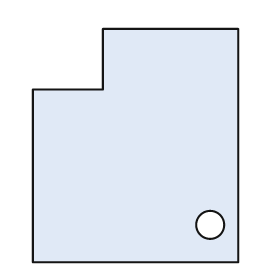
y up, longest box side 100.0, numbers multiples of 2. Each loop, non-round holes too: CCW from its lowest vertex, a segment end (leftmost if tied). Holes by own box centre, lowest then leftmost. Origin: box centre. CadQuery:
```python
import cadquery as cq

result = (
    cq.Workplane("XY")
    .moveTo(-44.0, -50.0)
    .lineTo(44.0, -50.0)
    .lineTo(44.0, 50.0)
    .lineTo(-14.0, 50.0)
    .lineTo(-14.0, 24.0)
    .lineTo(-44.0, 24.0)
    .close()
    .moveTo(32.0, -34.0)
    .circle(6.0)
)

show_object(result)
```